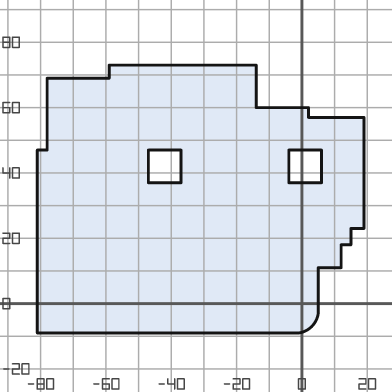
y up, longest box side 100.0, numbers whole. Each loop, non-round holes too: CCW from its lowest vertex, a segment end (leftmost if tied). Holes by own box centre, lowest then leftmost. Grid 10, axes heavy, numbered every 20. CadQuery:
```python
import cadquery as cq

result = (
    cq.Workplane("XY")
    .moveTo(-81.0, -9.0)
    .lineTo(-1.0, -9.0)
    .threePointArc((3.0, -7.0), (5.0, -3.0))
    .lineTo(5.0, 11.0)
    .lineTo(12.0, 11.0)
    .lineTo(12.0, 18.0)
    .lineTo(15.0, 18.0)
    .lineTo(15.0, 23.0)
    .lineTo(19.0, 23.0)
    .lineTo(19.0, 57.0)
    .lineTo(2.0, 57.0)
    .lineTo(2.0, 60.0)
    .lineTo(-14.0, 60.0)
    .lineTo(-14.0, 73.0)
    .lineTo(-59.0, 73.0)
    .lineTo(-59.0, 69.0)
    .lineTo(-78.0, 69.0)
    .lineTo(-78.0, 47.0)
    .lineTo(-81.0, 47.0)
    .close()
    .moveTo(-47.0, 37.0)
    .lineTo(-37.0, 37.0)
    .lineTo(-37.0, 47.0)
    .lineTo(-47.0, 47.0)
    .close()
    .moveTo(-4.0, 37.0)
    .lineTo(6.0, 37.0)
    .lineTo(6.0, 47.0)
    .lineTo(-4.0, 47.0)
    .close()
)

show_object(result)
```